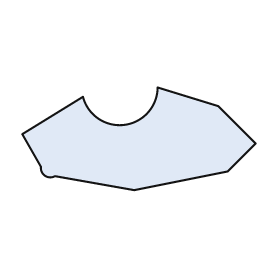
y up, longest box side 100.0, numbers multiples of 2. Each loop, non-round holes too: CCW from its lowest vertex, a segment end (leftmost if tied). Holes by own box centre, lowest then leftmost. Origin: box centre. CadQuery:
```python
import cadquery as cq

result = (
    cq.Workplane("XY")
    .moveTo(-2.0, -22.0)
    .lineTo(38.0, -14.0)
    .lineTo(50.0, -2.0)
    .lineTo(34.0, 14.0)
    .lineTo(8.0, 22.0)
    .threePointArc((-6.0, 6.0), (-24.0, 18.0))
    .lineTo(-50.0, 2.0)
    .lineTo(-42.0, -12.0)
    .threePointArc((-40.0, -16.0), (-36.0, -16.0))
    .close()
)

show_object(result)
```